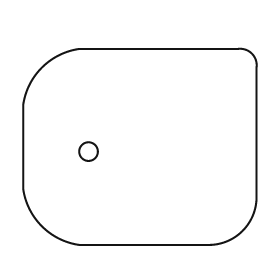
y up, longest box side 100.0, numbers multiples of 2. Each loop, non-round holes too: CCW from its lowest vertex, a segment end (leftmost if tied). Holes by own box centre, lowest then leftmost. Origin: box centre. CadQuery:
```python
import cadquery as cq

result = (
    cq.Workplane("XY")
    .moveTo(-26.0, -42.0)
    .lineTo(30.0, -42.0)
    .threePointArc((44.0, -36.0), (50.0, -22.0))
    .lineTo(50.0, 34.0)
    .threePointArc((48.0, 40.0), (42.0, 42.0))
    .lineTo(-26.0, 42.0)
    .threePointArc((-42.0, 34.0), (-50.0, 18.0))
    .lineTo(-50.0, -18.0)
    .threePointArc((-42.0, -34.0), (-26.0, -42.0))
    .close()
    .moveTo(-22.0, -2.0)
    .circle(4.0)
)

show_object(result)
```